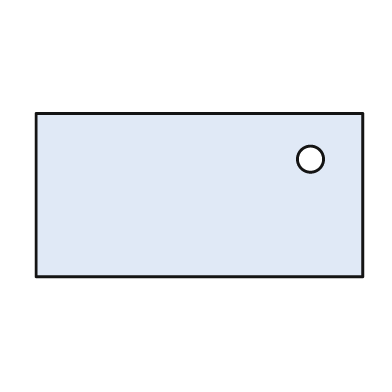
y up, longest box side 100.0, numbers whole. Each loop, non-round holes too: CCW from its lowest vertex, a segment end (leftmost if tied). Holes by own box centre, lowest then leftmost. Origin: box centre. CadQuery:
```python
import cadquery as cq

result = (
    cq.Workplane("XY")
    .moveTo(-50.0, -25.0)
    .lineTo(50.0, -25.0)
    .lineTo(50.0, 25.0)
    .lineTo(-50.0, 25.0)
    .close()
    .moveTo(34.0, 11.0)
    .circle(4.0)
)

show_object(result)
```